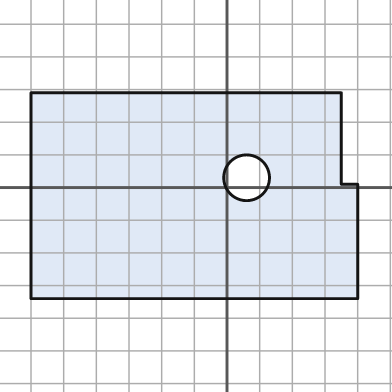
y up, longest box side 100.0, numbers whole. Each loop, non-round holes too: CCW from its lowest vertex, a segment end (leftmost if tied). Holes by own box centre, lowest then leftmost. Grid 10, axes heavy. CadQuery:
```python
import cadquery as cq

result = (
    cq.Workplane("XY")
    .moveTo(-60.0, -34.0)
    .lineTo(40.0, -34.0)
    .lineTo(40.0, 1.0)
    .lineTo(35.0, 1.0)
    .lineTo(35.0, 29.0)
    .lineTo(-60.0, 29.0)
    .close()
    .moveTo(6.0, 3.0)
    .circle(7.0)
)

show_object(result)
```